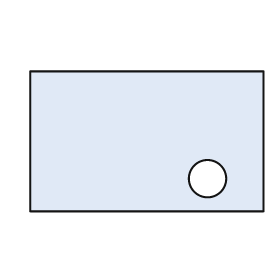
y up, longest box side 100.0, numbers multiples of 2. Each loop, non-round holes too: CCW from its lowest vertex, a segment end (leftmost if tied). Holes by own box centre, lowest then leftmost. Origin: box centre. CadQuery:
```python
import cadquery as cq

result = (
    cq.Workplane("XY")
    .moveTo(-50.0, -30.0)
    .lineTo(50.0, -30.0)
    .lineTo(50.0, 30.0)
    .lineTo(-50.0, 30.0)
    .close()
    .moveTo(26.0, -16.0)
    .circle(8.0)
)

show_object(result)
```